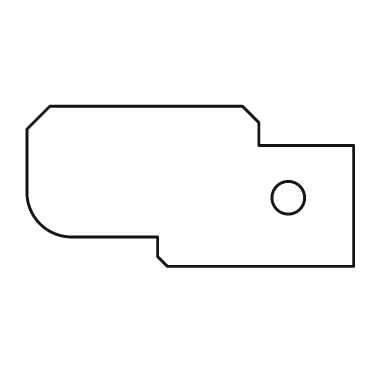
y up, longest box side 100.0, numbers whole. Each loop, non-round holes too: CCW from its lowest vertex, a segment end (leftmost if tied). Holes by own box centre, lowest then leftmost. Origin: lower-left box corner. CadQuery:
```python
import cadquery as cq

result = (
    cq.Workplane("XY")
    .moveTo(43.0, 0.0)
    .lineTo(100.0, 0.0)
    .lineTo(100.0, 37.0)
    .lineTo(71.0, 37.0)
    .lineTo(71.0, 44.0)
    .lineTo(66.0, 49.0)
    .lineTo(7.0, 49.0)
    .lineTo(0.0, 42.0)
    .lineTo(0.0, 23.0)
    .threePointArc((4.0, 13.0), (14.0, 9.0))
    .lineTo(40.0, 9.0)
    .lineTo(40.0, 3.0)
    .close()
    .moveTo(80.0, 21.0)
    .circle(5.0)
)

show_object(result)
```